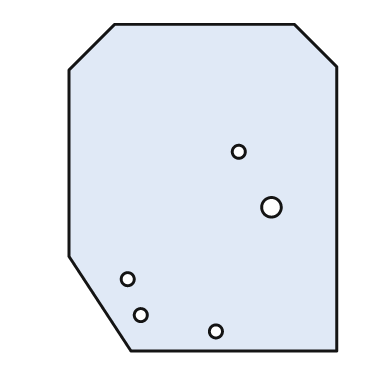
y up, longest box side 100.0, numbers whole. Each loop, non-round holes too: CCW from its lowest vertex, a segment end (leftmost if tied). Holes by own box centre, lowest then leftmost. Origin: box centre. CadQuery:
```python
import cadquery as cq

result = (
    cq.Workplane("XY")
    .moveTo(-22.0, -50.0)
    .lineTo(41.0, -50.0)
    .lineTo(41.0, 37.0)
    .lineTo(28.0, 50.0)
    .lineTo(-27.0, 50.0)
    .lineTo(-41.0, 36.0)
    .lineTo(-41.0, -21.0)
    .close()
    .moveTo(4.0, -44.0)
    .circle(2.0)
    .moveTo(-19.0, -39.0)
    .circle(2.0)
    .moveTo(-23.0, -28.0)
    .circle(2.0)
    .moveTo(21.0, -6.0)
    .circle(3.0)
    .moveTo(11.0, 11.0)
    .circle(2.0)
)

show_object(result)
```